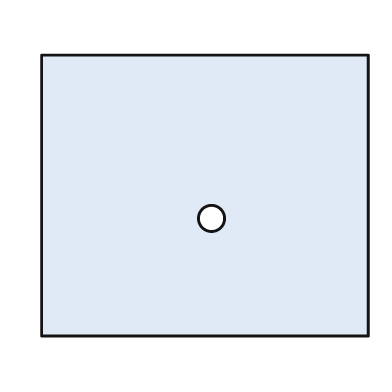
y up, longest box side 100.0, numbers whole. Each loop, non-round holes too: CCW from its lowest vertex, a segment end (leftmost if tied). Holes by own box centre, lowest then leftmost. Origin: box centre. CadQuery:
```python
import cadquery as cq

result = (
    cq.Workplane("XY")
    .moveTo(-50.0, -43.0)
    .lineTo(50.0, -43.0)
    .lineTo(50.0, 43.0)
    .lineTo(-50.0, 43.0)
    .close()
    .moveTo(2.0, -7.0)
    .circle(4.0)
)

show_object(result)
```